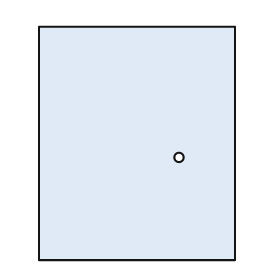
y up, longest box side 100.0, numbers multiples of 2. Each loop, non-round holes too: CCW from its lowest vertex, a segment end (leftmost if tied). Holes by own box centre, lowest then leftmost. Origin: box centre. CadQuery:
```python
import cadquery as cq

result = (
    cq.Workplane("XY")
    .moveTo(-42.0, -50.0)
    .lineTo(42.0, -50.0)
    .lineTo(42.0, 50.0)
    .lineTo(-42.0, 50.0)
    .close()
    .moveTo(18.0, -6.0)
    .circle(2.0)
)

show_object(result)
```